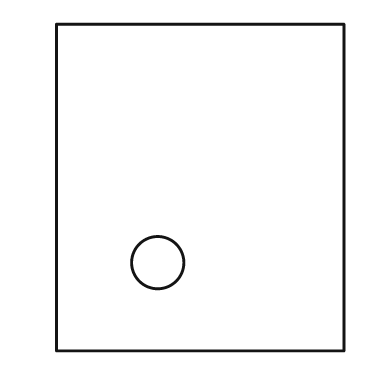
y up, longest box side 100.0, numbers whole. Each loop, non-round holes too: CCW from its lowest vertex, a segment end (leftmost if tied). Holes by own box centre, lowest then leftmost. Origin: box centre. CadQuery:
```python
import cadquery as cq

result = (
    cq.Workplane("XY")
    .moveTo(-44.0, -50.0)
    .lineTo(44.0, -50.0)
    .lineTo(44.0, 50.0)
    .lineTo(-44.0, 50.0)
    .close()
    .moveTo(-13.0, -23.0)
    .circle(8.0)
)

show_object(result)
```